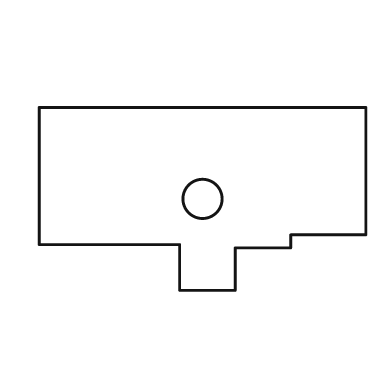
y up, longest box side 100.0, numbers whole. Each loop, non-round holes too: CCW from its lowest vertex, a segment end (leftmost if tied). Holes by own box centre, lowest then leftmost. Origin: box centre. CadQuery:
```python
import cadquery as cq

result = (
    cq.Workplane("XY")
    .moveTo(-7.0, -28.0)
    .lineTo(10.0, -28.0)
    .lineTo(10.0, -15.0)
    .lineTo(27.0, -15.0)
    .lineTo(27.0, -11.0)
    .lineTo(50.0, -11.0)
    .lineTo(50.0, 28.0)
    .lineTo(-50.0, 28.0)
    .lineTo(-50.0, -14.0)
    .lineTo(-7.0, -14.0)
    .close()
    .moveTo(0.0, 0.0)
    .circle(6.0)
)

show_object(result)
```